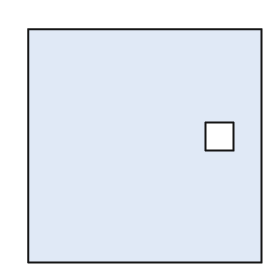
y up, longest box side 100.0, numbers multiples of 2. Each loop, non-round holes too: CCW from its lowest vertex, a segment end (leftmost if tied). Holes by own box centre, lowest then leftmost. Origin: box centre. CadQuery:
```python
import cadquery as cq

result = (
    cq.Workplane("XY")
    .moveTo(-50.0, -50.0)
    .lineTo(50.0, -50.0)
    .lineTo(50.0, 50.0)
    .lineTo(-50.0, 50.0)
    .close()
    .moveTo(26.0, -2.0)
    .lineTo(38.0, -2.0)
    .lineTo(38.0, 10.0)
    .lineTo(26.0, 10.0)
    .close()
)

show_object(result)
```